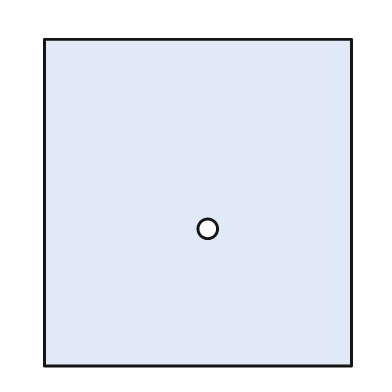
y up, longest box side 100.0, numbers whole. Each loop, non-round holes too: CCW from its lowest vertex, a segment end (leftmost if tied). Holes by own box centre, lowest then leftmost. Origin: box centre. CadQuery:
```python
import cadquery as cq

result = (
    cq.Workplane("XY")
    .moveTo(-47.0, -50.0)
    .lineTo(47.0, -50.0)
    .lineTo(47.0, 50.0)
    .lineTo(-47.0, 50.0)
    .close()
    .moveTo(3.0, -8.0)
    .circle(3.0)
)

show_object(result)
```